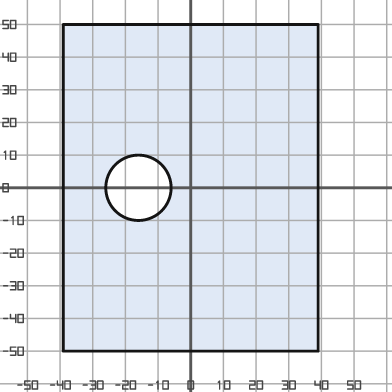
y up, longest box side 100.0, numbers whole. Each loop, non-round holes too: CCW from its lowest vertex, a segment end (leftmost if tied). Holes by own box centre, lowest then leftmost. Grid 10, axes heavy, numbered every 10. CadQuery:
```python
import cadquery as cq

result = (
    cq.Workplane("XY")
    .moveTo(-39.0, -50.0)
    .lineTo(39.0, -50.0)
    .lineTo(39.0, 50.0)
    .lineTo(-39.0, 50.0)
    .close()
    .moveTo(-16.0, 0.0)
    .circle(10.0)
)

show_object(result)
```